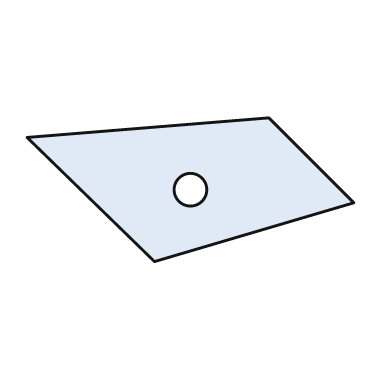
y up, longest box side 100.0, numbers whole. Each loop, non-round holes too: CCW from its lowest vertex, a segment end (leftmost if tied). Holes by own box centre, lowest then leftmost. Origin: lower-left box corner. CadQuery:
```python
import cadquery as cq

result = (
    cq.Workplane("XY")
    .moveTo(39.0, 0.0)
    .lineTo(100.0, 18.0)
    .lineTo(74.0, 44.0)
    .lineTo(0.0, 38.0)
    .close()
    .moveTo(50.0, 22.0)
    .circle(5.0)
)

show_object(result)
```